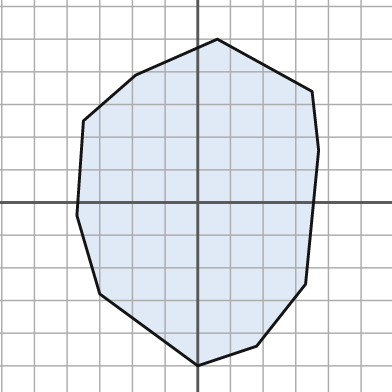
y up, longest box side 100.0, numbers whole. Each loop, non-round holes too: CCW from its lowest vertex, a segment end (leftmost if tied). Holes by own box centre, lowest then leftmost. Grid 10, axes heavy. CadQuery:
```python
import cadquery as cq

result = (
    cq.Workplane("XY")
    .moveTo(0.0, -50.0)
    .lineTo(18.0, -44.0)
    .lineTo(33.0, -25.0)
    .lineTo(37.0, 16.0)
    .lineTo(35.0, 34.0)
    .lineTo(6.0, 50.0)
    .lineTo(-19.0, 39.0)
    .lineTo(-35.0, 25.0)
    .lineTo(-37.0, -4.0)
    .lineTo(-30.0, -28.0)
    .close()
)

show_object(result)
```